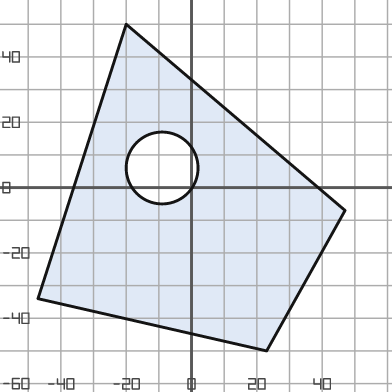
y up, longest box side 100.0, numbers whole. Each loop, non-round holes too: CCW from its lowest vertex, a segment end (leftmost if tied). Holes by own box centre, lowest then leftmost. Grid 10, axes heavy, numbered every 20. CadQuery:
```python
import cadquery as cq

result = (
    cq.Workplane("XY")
    .moveTo(23.0, -50.0)
    .lineTo(47.0, -7.0)
    .lineTo(-20.0, 50.0)
    .lineTo(-47.0, -34.0)
    .close()
    .moveTo(-9.0, 6.0)
    .circle(11.0)
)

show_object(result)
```